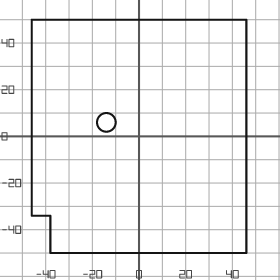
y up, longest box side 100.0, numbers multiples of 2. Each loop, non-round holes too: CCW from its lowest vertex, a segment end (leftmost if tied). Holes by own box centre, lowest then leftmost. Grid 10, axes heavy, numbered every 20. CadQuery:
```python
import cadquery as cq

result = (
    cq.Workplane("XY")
    .moveTo(-38.0, -50.0)
    .lineTo(46.0, -50.0)
    .lineTo(46.0, 50.0)
    .lineTo(-46.0, 50.0)
    .lineTo(-46.0, -34.0)
    .lineTo(-38.0, -34.0)
    .close()
    .moveTo(-14.0, 6.0)
    .circle(4.0)
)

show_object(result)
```